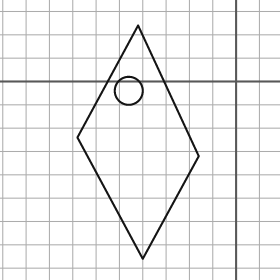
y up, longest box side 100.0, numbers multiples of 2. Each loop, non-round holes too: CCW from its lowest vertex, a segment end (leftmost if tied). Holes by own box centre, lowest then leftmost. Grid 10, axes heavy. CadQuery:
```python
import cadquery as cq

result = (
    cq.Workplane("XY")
    .moveTo(-40.0, -76.0)
    .lineTo(-16.0, -32.0)
    .lineTo(-42.0, 24.0)
    .lineTo(-68.0, -24.0)
    .close()
    .moveTo(-46.0, -4.0)
    .circle(6.0)
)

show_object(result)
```